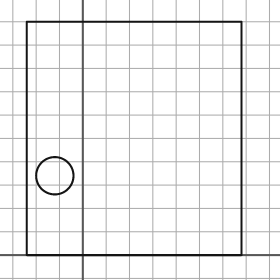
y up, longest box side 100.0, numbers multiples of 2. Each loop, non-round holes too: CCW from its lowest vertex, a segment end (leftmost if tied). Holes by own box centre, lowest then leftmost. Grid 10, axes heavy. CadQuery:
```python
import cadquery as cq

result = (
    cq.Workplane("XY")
    .moveTo(-24.0, 0.0)
    .lineTo(68.0, 0.0)
    .lineTo(68.0, 100.0)
    .lineTo(-24.0, 100.0)
    .close()
    .moveTo(-12.0, 34.0)
    .circle(8.0)
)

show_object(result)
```